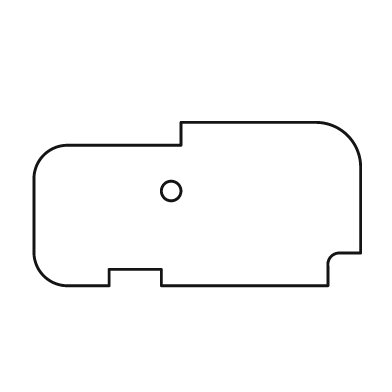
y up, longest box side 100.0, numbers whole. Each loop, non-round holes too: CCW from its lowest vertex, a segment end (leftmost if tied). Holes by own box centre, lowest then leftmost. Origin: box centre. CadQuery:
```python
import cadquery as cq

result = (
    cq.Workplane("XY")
    .moveTo(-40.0, -25.0)
    .lineTo(-27.0, -25.0)
    .lineTo(-27.0, -20.0)
    .lineTo(-11.0, -20.0)
    .lineTo(-11.0, -25.0)
    .lineTo(40.0, -25.0)
    .lineTo(40.0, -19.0)
    .threePointArc((41.0, -16.0), (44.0, -15.0))
    .lineTo(50.0, -15.0)
    .lineTo(50.0, 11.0)
    .threePointArc((46.0, 21.0), (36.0, 25.0))
    .lineTo(-5.0, 25.0)
    .lineTo(-5.0, 18.0)
    .lineTo(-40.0, 18.0)
    .threePointArc((-47.0, 15.0), (-50.0, 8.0))
    .lineTo(-50.0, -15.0)
    .threePointArc((-47.0, -22.0), (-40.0, -25.0))
    .close()
    .moveTo(-8.0, 4.0)
    .circle(3.0)
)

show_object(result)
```